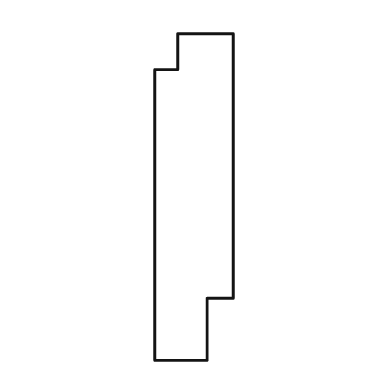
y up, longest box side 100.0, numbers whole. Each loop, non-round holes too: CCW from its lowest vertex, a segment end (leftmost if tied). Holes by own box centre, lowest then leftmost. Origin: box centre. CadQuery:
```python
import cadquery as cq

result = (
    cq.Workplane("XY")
    .moveTo(-12.0, -50.0)
    .lineTo(4.0, -50.0)
    .lineTo(4.0, -31.0)
    .lineTo(12.0, -31.0)
    .lineTo(12.0, 50.0)
    .lineTo(-5.0, 50.0)
    .lineTo(-5.0, 39.0)
    .lineTo(-12.0, 39.0)
    .close()
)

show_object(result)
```